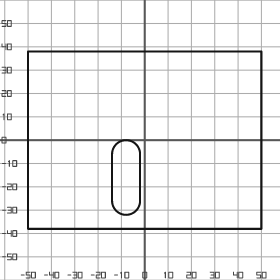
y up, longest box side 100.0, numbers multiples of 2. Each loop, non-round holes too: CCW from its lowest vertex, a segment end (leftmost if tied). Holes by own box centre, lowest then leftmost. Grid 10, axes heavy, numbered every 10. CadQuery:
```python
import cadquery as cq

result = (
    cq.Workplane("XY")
    .moveTo(-50.0, -38.0)
    .lineTo(50.0, -38.0)
    .lineTo(50.0, 38.0)
    .lineTo(-50.0, 38.0)
    .close()
    .moveTo(-14.0, -26.0)
    .threePointArc((-8.0, -32.0), (-2.0, -26.0))
    .lineTo(-2.0, -6.0)
    .threePointArc((-8.0, 0.0), (-14.0, -6.0))
    .close()
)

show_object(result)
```